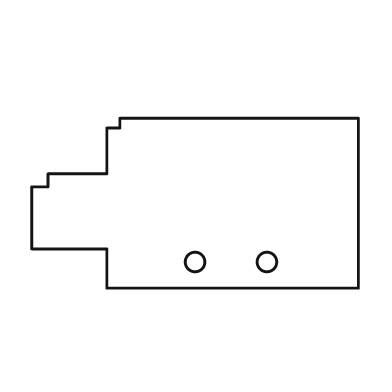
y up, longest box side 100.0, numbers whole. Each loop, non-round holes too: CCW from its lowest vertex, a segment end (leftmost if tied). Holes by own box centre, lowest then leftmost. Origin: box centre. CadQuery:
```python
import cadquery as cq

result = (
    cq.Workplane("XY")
    .moveTo(-27.0, -26.0)
    .lineTo(50.0, -26.0)
    .lineTo(50.0, 26.0)
    .lineTo(-23.0, 26.0)
    .lineTo(-23.0, 23.0)
    .lineTo(-27.0, 23.0)
    .lineTo(-27.0, 9.0)
    .lineTo(-45.0, 9.0)
    .lineTo(-45.0, 5.0)
    .lineTo(-50.0, 5.0)
    .lineTo(-50.0, -14.0)
    .lineTo(-27.0, -14.0)
    .close()
    .moveTo(0.0, -18.0)
    .circle(3.0)
    .moveTo(22.0, -18.0)
    .circle(3.0)
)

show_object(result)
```